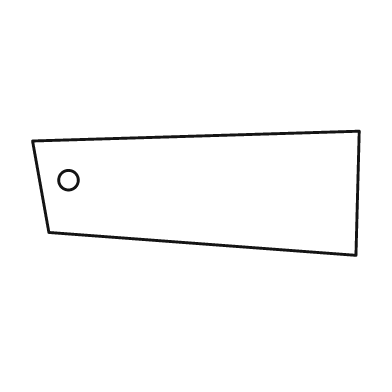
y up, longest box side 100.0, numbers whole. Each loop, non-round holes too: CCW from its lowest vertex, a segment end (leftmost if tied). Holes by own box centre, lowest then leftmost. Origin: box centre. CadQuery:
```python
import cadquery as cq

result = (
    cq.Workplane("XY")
    .moveTo(49.0, -19.0)
    .lineTo(50.0, 19.0)
    .lineTo(-50.0, 16.0)
    .lineTo(-45.0, -12.0)
    .close()
    .moveTo(-39.0, 4.0)
    .circle(3.0)
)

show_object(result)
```